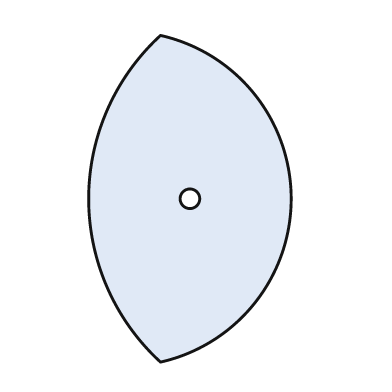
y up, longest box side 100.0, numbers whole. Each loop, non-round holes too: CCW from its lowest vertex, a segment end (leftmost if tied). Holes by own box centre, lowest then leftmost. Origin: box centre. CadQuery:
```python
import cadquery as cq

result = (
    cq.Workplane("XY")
    .moveTo(-9.0, -50.0)
    .threePointArc((31.0, 0.0), (-9.0, 50.0))
    .threePointArc((-31.0, 0.0), (-9.0, -50.0))
    .close()
    .moveTo(0.0, 0.0)
    .circle(3.0)
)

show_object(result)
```